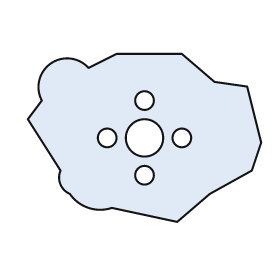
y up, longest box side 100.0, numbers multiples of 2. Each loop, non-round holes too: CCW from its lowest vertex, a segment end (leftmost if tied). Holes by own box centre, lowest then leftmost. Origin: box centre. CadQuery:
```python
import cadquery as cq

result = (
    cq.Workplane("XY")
    .moveTo(14.0, -36.0)
    .lineTo(28.0, -24.0)
    .lineTo(46.0, -14.0)
    .lineTo(50.0, -2.0)
    .lineTo(44.0, 22.0)
    .lineTo(30.0, 24.0)
    .lineTo(16.0, 36.0)
    .lineTo(-12.0, 36.0)
    .lineTo(-24.0, 30.0)
    .threePointArc((-40.0, 32.0), (-44.0, 16.0))
    .lineTo(-50.0, 8.0)
    .lineTo(-36.0, -14.0)
    .threePointArc((-36.0, -20.0), (-32.0, -24.0))
    .threePointArc((-24.0, -30.0), (-14.0, -30.0))
    .close()
    .moveTo(0.0, -16.0)
    .circle(4.0)
    .moveTo(-16.0, 0.0)
    .circle(4.0)
    .moveTo(0.0, 0.0)
    .circle(8.0)
    .moveTo(16.0, 0.0)
    .circle(4.0)
    .moveTo(0.0, 16.0)
    .circle(4.0)
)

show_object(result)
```